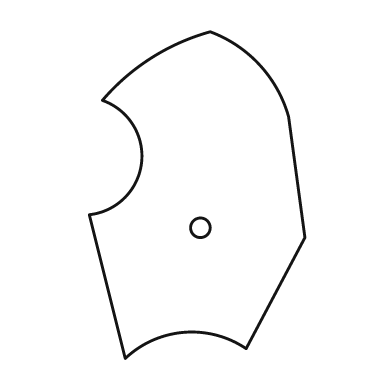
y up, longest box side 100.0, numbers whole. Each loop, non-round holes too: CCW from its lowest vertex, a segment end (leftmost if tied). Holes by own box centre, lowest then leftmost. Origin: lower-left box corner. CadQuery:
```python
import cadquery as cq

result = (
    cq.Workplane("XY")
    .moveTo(11.0, 0.0)
    .threePointArc((29.0, 8.0), (48.0, 3.0))
    .lineTo(66.0, 37.0)
    .lineTo(61.0, 74.0)
    .threePointArc((52.0, 90.0), (37.0, 100.0))
    .threePointArc((19.0, 92.0), (4.0, 79.0))
    .threePointArc((16.0, 60.0), (0.0, 44.0))
    .close()
    .moveTo(34.0, 40.0)
    .circle(3.0)
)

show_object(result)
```